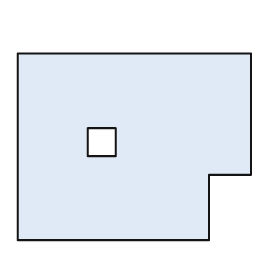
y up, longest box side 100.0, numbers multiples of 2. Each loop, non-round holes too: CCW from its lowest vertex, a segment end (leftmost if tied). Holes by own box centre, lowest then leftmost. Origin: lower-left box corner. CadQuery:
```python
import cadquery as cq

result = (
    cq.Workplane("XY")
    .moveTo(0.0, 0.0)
    .lineTo(82.0, 0.0)
    .lineTo(82.0, 28.0)
    .lineTo(100.0, 28.0)
    .lineTo(100.0, 80.0)
    .lineTo(0.0, 80.0)
    .close()
    .moveTo(30.0, 36.0)
    .lineTo(42.0, 36.0)
    .lineTo(42.0, 48.0)
    .lineTo(30.0, 48.0)
    .close()
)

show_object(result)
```